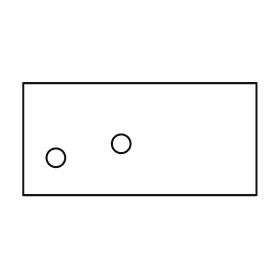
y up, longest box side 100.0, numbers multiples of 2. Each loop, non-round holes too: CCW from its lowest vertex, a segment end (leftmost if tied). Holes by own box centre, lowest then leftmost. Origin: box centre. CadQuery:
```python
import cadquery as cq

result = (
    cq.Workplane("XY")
    .moveTo(-50.0, -24.0)
    .lineTo(50.0, -24.0)
    .lineTo(50.0, 24.0)
    .lineTo(-50.0, 24.0)
    .close()
    .moveTo(-36.0, -8.0)
    .circle(4.0)
    .moveTo(-8.0, -2.0)
    .circle(4.0)
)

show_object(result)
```